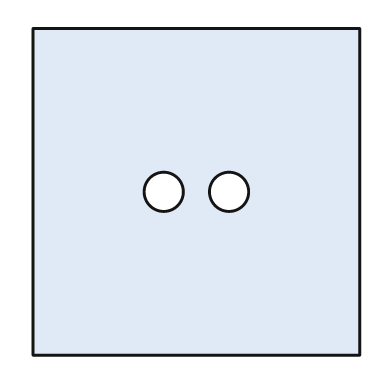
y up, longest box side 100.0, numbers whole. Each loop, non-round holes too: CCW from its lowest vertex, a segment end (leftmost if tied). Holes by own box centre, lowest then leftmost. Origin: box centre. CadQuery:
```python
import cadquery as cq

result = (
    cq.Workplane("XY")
    .moveTo(-50.0, -50.0)
    .lineTo(50.0, -50.0)
    .lineTo(50.0, 50.0)
    .lineTo(-50.0, 50.0)
    .close()
    .moveTo(-10.0, 0.0)
    .circle(6.0)
    .moveTo(10.0, 0.0)
    .circle(6.0)
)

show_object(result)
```